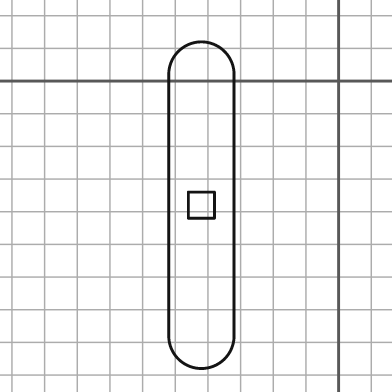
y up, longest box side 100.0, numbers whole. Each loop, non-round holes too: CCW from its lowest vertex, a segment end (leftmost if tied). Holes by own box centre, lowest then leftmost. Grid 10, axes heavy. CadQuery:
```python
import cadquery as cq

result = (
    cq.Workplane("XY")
    .moveTo(-52.0, -78.0)
    .threePointArc((-42.0, -88.0), (-32.0, -78.0))
    .lineTo(-32.0, 2.0)
    .threePointArc((-42.0, 12.0), (-52.0, 2.0))
    .close()
    .moveTo(-46.0, -42.0)
    .lineTo(-38.0, -42.0)
    .lineTo(-38.0, -34.0)
    .lineTo(-46.0, -34.0)
    .close()
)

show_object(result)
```